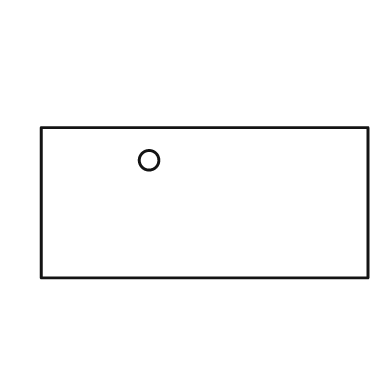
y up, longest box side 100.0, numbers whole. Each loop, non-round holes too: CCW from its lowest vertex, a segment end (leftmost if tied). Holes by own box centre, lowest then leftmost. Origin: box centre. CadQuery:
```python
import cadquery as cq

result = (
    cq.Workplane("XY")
    .moveTo(-50.0, -23.0)
    .lineTo(50.0, -23.0)
    .lineTo(50.0, 23.0)
    .lineTo(-50.0, 23.0)
    .close()
    .moveTo(-17.0, 13.0)
    .circle(3.0)
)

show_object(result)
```